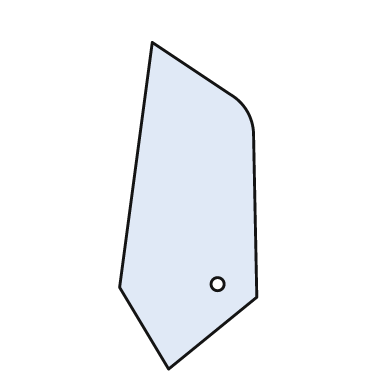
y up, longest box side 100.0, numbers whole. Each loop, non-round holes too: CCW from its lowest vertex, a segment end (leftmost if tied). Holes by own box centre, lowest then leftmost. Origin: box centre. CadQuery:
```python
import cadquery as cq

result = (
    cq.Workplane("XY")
    .moveTo(-6.0, -50.0)
    .lineTo(21.0, -28.0)
    .lineTo(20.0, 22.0)
    .threePointArc((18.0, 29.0), (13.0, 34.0))
    .lineTo(-11.0, 50.0)
    .lineTo(-21.0, -25.0)
    .close()
    .moveTo(9.0, -24.0)
    .circle(2.0)
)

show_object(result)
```